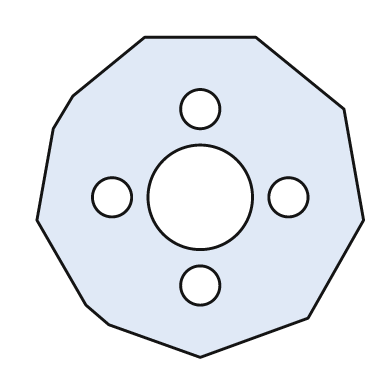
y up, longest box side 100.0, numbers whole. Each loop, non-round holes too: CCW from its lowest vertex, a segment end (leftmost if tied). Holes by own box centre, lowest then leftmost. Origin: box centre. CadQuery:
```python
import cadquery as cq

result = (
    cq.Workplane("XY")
    .moveTo(0.0, -49.0)
    .lineTo(33.0, -37.0)
    .lineTo(50.0, -7.0)
    .lineTo(44.0, 27.0)
    .lineTo(17.0, 49.0)
    .lineTo(-17.0, 49.0)
    .lineTo(-39.0, 31.0)
    .lineTo(-45.0, 21.0)
    .lineTo(-50.0, -7.0)
    .lineTo(-35.0, -33.0)
    .lineTo(-28.0, -39.0)
    .close()
    .moveTo(0.0, -27.0)
    .circle(6.0)
    .moveTo(-27.0, 0.0)
    .circle(6.0)
    .moveTo(0.0, 0.0)
    .circle(16.0)
    .moveTo(27.0, 0.0)
    .circle(6.0)
    .moveTo(0.0, 27.0)
    .circle(6.0)
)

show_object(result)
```